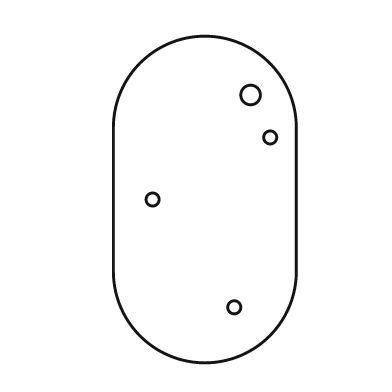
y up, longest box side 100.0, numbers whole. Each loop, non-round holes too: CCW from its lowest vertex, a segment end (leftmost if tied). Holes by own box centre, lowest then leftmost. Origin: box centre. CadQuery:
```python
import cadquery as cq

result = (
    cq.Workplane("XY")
    .moveTo(-28.0, -22.0)
    .threePointArc((0.0, -50.0), (28.0, -22.0))
    .lineTo(28.0, 22.0)
    .threePointArc((0.0, 50.0), (-28.0, 22.0))
    .close()
    .moveTo(9.0, -33.0)
    .circle(2.0)
    .moveTo(-16.0, 0.0)
    .circle(2.0)
    .moveTo(20.0, 19.0)
    .circle(2.0)
    .moveTo(14.0, 32.0)
    .circle(3.0)
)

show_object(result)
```